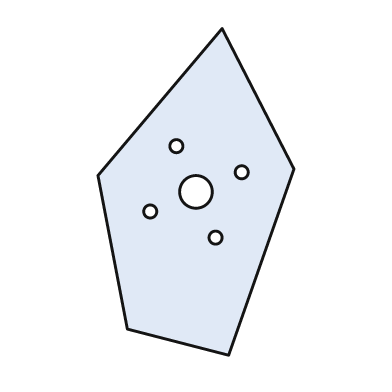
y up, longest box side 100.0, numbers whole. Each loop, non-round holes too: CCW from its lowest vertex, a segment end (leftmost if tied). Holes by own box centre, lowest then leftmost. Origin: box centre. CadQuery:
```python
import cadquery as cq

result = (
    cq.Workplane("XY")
    .moveTo(10.0, -50.0)
    .lineTo(30.0, 7.0)
    .lineTo(8.0, 50.0)
    .lineTo(-30.0, 5.0)
    .lineTo(-21.0, -42.0)
    .close()
    .moveTo(6.0, -14.0)
    .circle(2.0)
    .moveTo(-14.0, -6.0)
    .circle(2.0)
    .moveTo(0.0, 0.0)
    .circle(5.0)
    .moveTo(14.0, 6.0)
    .circle(2.0)
    .moveTo(-6.0, 14.0)
    .circle(2.0)
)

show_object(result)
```